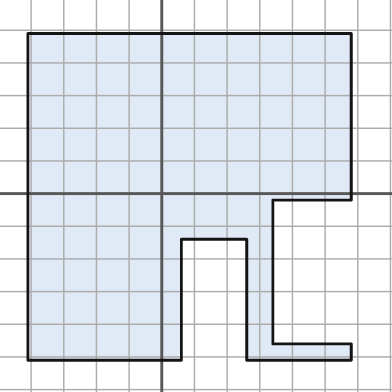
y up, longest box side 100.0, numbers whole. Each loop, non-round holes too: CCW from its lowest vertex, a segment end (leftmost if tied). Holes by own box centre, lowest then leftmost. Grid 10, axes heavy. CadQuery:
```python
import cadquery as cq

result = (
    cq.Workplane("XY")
    .moveTo(-41.0, -51.0)
    .lineTo(6.0, -51.0)
    .lineTo(6.0, -14.0)
    .lineTo(26.0, -14.0)
    .lineTo(26.0, -51.0)
    .lineTo(58.0, -51.0)
    .lineTo(58.0, -46.0)
    .lineTo(34.0, -46.0)
    .lineTo(34.0, -2.0)
    .lineTo(58.0, -2.0)
    .lineTo(58.0, 49.0)
    .lineTo(-41.0, 49.0)
    .close()
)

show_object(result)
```